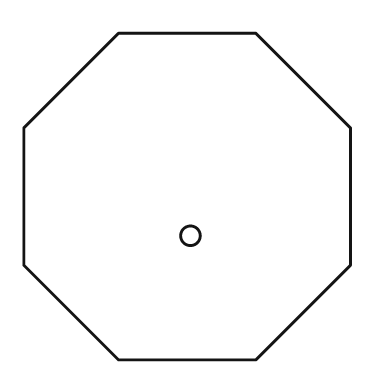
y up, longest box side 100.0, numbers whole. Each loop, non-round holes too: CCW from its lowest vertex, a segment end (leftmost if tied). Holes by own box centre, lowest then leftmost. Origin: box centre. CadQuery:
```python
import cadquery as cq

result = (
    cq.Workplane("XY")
    .moveTo(-21.0, -50.0)
    .lineTo(21.0, -50.0)
    .lineTo(50.0, -21.0)
    .lineTo(50.0, 21.0)
    .lineTo(21.0, 50.0)
    .lineTo(-21.0, 50.0)
    .lineTo(-50.0, 21.0)
    .lineTo(-50.0, -21.0)
    .close()
    .moveTo(1.0, -12.0)
    .circle(3.0)
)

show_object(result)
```